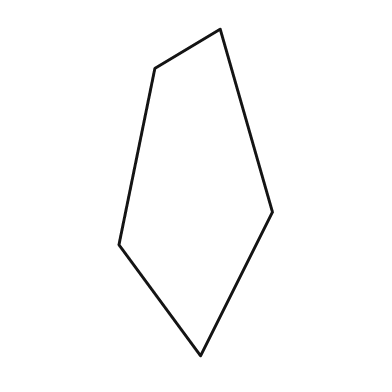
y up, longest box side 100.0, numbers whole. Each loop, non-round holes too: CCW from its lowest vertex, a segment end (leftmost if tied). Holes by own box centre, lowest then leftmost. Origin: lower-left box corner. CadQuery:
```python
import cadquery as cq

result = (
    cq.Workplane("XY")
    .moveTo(25.0, 0.0)
    .lineTo(47.0, 44.0)
    .lineTo(31.0, 100.0)
    .lineTo(11.0, 88.0)
    .lineTo(0.0, 34.0)
    .close()
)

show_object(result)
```